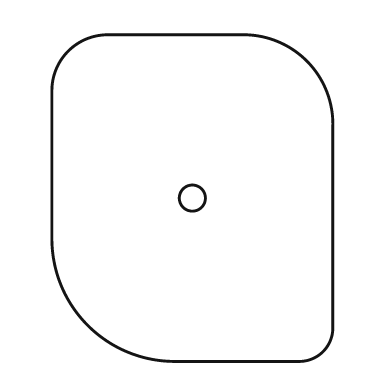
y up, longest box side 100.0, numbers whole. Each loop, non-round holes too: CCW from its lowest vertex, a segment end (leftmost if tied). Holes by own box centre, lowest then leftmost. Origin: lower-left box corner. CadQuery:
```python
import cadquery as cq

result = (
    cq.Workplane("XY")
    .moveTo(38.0, 0.0)
    .lineTo(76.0, 0.0)
    .threePointArc((83.0, 3.0), (86.0, 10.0))
    .lineTo(86.0, 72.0)
    .threePointArc((78.0, 92.0), (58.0, 100.0))
    .lineTo(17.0, 100.0)
    .threePointArc((5.0, 95.0), (0.0, 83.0))
    .lineTo(0.0, 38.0)
    .threePointArc((11.0, 11.0), (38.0, 0.0))
    .close()
    .moveTo(43.0, 50.0)
    .circle(4.0)
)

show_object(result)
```